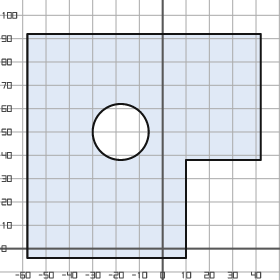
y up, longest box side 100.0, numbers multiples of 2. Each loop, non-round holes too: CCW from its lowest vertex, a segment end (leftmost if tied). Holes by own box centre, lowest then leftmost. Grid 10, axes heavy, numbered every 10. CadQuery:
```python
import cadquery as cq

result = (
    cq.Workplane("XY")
    .moveTo(-58.0, -4.0)
    .lineTo(10.0, -4.0)
    .lineTo(10.0, 38.0)
    .lineTo(42.0, 38.0)
    .lineTo(42.0, 92.0)
    .lineTo(-58.0, 92.0)
    .close()
    .moveTo(-18.0, 50.0)
    .circle(12.0)
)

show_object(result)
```